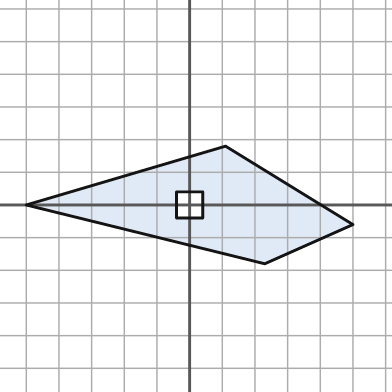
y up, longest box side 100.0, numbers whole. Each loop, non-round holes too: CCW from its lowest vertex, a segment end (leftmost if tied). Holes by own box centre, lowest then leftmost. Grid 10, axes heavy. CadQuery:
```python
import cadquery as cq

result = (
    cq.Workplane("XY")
    .moveTo(23.0, -18.0)
    .lineTo(50.0, -6.0)
    .lineTo(11.0, 18.0)
    .lineTo(-50.0, 0.0)
    .close()
    .moveTo(-4.0, -4.0)
    .lineTo(4.0, -4.0)
    .lineTo(4.0, 4.0)
    .lineTo(-4.0, 4.0)
    .close()
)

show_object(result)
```